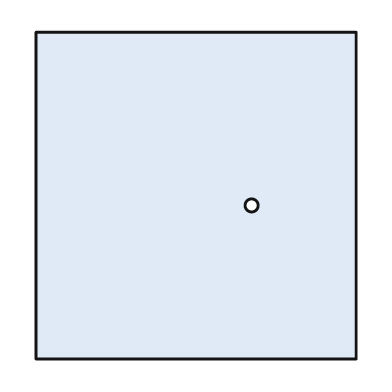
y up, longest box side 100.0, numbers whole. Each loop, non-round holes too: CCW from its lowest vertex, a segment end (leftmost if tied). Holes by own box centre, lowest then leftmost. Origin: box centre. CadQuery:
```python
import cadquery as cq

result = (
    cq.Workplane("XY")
    .moveTo(-49.0, -50.0)
    .lineTo(49.0, -50.0)
    .lineTo(49.0, 50.0)
    .lineTo(-49.0, 50.0)
    .close()
    .moveTo(17.0, -3.0)
    .circle(2.0)
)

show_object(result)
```